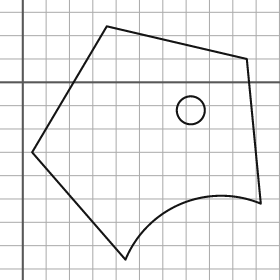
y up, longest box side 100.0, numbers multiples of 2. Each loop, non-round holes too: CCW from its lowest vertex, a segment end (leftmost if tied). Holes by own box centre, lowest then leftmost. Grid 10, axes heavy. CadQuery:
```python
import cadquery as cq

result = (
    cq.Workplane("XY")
    .moveTo(44.0, -76.0)
    .threePointArc((68.0, -52.0), (102.0, -52.0))
    .lineTo(96.0, 10.0)
    .lineTo(36.0, 24.0)
    .lineTo(4.0, -30.0)
    .close()
    .moveTo(72.0, -12.0)
    .circle(6.0)
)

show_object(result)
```